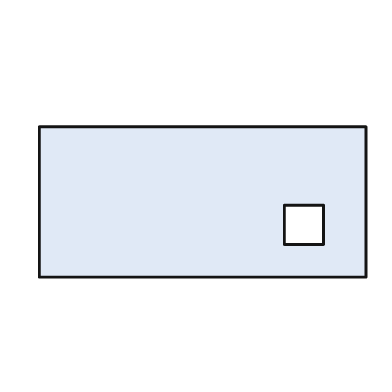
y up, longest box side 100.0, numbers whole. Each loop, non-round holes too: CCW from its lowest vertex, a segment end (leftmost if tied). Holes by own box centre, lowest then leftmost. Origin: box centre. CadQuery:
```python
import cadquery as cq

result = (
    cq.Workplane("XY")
    .moveTo(-50.0, -23.0)
    .lineTo(50.0, -23.0)
    .lineTo(50.0, 23.0)
    .lineTo(-50.0, 23.0)
    .close()
    .moveTo(25.0, -13.0)
    .lineTo(37.0, -13.0)
    .lineTo(37.0, -1.0)
    .lineTo(25.0, -1.0)
    .close()
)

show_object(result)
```